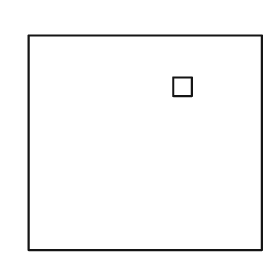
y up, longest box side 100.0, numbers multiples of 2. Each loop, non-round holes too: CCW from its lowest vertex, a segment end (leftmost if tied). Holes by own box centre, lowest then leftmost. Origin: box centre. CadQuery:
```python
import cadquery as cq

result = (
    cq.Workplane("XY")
    .moveTo(-50.0, -46.0)
    .lineTo(50.0, -46.0)
    .lineTo(50.0, 46.0)
    .lineTo(-50.0, 46.0)
    .close()
    .moveTo(12.0, 20.0)
    .lineTo(20.0, 20.0)
    .lineTo(20.0, 28.0)
    .lineTo(12.0, 28.0)
    .close()
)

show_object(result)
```